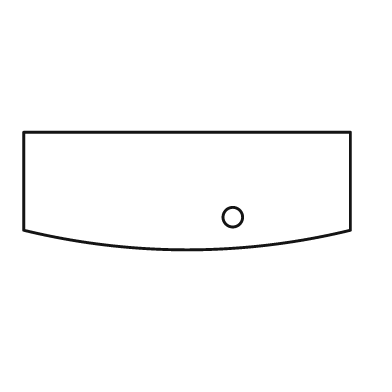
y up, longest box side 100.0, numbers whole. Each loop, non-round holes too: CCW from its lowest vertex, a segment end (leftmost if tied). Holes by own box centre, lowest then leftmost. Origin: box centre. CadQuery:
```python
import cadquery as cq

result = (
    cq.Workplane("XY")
    .moveTo(-50.0, -12.0)
    .threePointArc((0.0, -18.0), (50.0, -12.0))
    .lineTo(50.0, 18.0)
    .lineTo(-50.0, 18.0)
    .close()
    .moveTo(14.0, -8.0)
    .circle(3.0)
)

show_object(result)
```